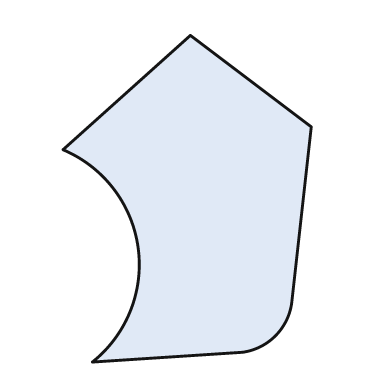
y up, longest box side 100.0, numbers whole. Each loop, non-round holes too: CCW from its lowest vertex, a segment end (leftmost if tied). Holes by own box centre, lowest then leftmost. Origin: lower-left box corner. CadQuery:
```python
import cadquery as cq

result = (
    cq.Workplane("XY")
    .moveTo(9.0, 0.0)
    .lineTo(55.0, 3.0)
    .threePointArc((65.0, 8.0), (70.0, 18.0))
    .lineTo(76.0, 72.0)
    .lineTo(39.0, 100.0)
    .lineTo(0.0, 65.0)
    .threePointArc((23.0, 35.0), (9.0, 0.0))
    .close()
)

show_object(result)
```